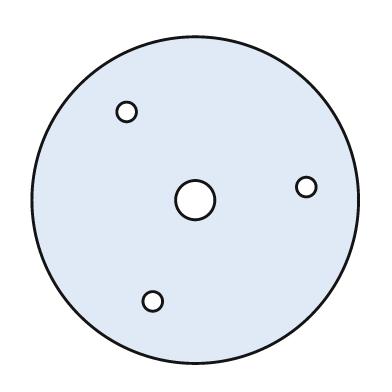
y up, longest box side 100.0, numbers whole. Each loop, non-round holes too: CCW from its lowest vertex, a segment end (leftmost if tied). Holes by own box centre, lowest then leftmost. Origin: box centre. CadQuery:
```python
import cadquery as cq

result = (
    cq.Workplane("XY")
    .moveTo(0.0, 0.0)
    .circle(50.0)
    .moveTo(-13.0, -31.0)
    .circle(3.0)
    .moveTo(0.0, 0.0)
    .circle(6.0)
    .moveTo(34.0, 4.0)
    .circle(3.0)
    .moveTo(-21.0, 27.0)
    .circle(3.0)
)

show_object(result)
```